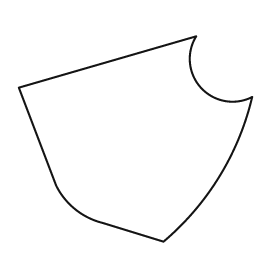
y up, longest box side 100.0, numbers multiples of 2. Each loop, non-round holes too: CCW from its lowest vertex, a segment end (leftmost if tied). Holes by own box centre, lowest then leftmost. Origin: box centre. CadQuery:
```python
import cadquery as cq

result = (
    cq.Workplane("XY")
    .moveTo(12.0, -44.0)
    .threePointArc((36.0, -16.0), (50.0, 18.0))
    .threePointArc((28.0, 22.0), (26.0, 44.0))
    .lineTo(-50.0, 22.0)
    .lineTo(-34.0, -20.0)
    .threePointArc((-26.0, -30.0), (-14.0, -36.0))
    .close()
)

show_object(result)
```